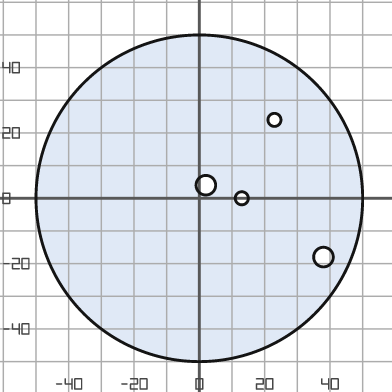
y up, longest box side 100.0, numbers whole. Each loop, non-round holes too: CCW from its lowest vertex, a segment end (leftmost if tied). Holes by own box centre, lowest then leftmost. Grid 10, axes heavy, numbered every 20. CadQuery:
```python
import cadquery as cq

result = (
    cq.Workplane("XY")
    .moveTo(0.0, 0.0)
    .circle(50.0)
    .moveTo(38.0, -18.0)
    .circle(3.0)
    .moveTo(13.0, 0.0)
    .circle(2.0)
    .moveTo(2.0, 4.0)
    .circle(3.0)
    .moveTo(23.0, 24.0)
    .circle(2.0)
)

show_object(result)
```